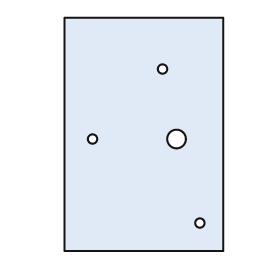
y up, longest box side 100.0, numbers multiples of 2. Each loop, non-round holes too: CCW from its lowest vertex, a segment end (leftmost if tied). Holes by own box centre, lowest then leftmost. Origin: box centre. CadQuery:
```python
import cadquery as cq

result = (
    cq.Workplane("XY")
    .moveTo(-34.0, -50.0)
    .lineTo(34.0, -50.0)
    .lineTo(34.0, 50.0)
    .lineTo(-34.0, 50.0)
    .close()
    .moveTo(24.0, -38.0)
    .circle(2.0)
    .moveTo(-22.0, -2.0)
    .circle(2.0)
    .moveTo(14.0, -2.0)
    .circle(4.0)
    .moveTo(8.0, 28.0)
    .circle(2.0)
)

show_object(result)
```